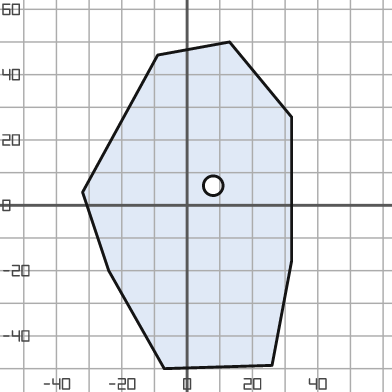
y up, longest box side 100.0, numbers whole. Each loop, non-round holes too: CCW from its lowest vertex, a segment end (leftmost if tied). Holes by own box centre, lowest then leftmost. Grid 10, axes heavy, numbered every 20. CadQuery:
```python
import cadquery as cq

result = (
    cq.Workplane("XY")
    .moveTo(-7.0, -50.0)
    .lineTo(26.0, -49.0)
    .lineTo(32.0, -17.0)
    .lineTo(32.0, 27.0)
    .lineTo(13.0, 50.0)
    .lineTo(-9.0, 46.0)
    .lineTo(-32.0, 4.0)
    .lineTo(-24.0, -20.0)
    .close()
    .moveTo(8.0, 6.0)
    .circle(3.0)
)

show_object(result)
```